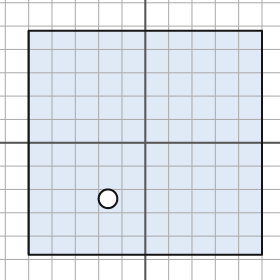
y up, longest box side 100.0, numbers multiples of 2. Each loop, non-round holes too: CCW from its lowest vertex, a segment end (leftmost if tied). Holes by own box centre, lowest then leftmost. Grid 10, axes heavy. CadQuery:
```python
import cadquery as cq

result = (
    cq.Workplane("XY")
    .moveTo(-50.0, -48.0)
    .lineTo(50.0, -48.0)
    .lineTo(50.0, 48.0)
    .lineTo(-50.0, 48.0)
    .close()
    .moveTo(-16.0, -24.0)
    .circle(4.0)
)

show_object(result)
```